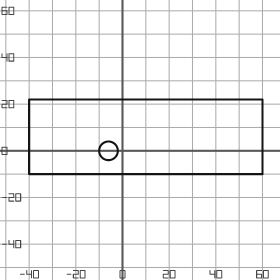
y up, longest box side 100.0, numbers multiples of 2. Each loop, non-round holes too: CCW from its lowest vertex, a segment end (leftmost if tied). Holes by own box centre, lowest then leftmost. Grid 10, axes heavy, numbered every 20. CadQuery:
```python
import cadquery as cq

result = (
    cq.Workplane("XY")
    .moveTo(-40.0, -10.0)
    .lineTo(60.0, -10.0)
    .lineTo(60.0, 22.0)
    .lineTo(-40.0, 22.0)
    .close()
    .moveTo(-6.0, 0.0)
    .circle(4.0)
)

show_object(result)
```